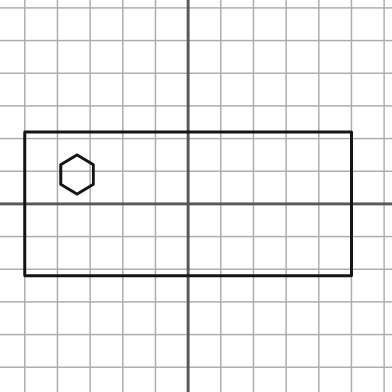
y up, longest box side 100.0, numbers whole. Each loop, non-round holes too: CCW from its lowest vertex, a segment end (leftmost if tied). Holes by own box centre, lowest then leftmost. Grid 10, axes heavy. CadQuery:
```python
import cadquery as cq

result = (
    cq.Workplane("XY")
    .moveTo(-50.0, -22.0)
    .lineTo(50.0, -22.0)
    .lineTo(50.0, 22.0)
    .lineTo(-50.0, 22.0)
    .close()
    .moveTo(-34.0, 3.0)
    .lineTo(-29.0, 6.0)
    .lineTo(-29.0, 12.0)
    .lineTo(-34.0, 15.0)
    .lineTo(-39.0, 12.0)
    .lineTo(-39.0, 6.0)
    .close()
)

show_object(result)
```